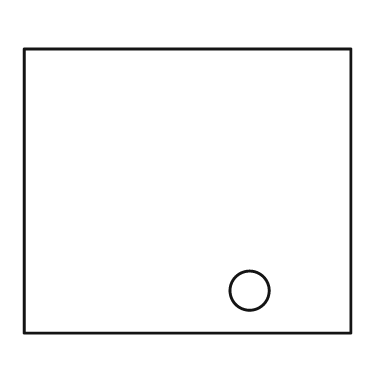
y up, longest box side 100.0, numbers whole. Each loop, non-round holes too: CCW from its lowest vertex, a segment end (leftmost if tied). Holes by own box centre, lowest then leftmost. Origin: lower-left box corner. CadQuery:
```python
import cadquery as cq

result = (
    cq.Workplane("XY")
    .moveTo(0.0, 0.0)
    .lineTo(100.0, 0.0)
    .lineTo(100.0, 87.0)
    .lineTo(0.0, 87.0)
    .close()
    .moveTo(69.0, 13.0)
    .circle(6.0)
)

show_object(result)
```